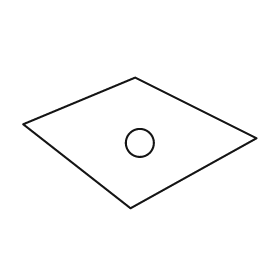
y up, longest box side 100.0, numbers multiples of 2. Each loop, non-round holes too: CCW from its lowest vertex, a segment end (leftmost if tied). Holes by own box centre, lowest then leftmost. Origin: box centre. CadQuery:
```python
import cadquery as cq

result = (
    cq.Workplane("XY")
    .moveTo(-4.0, -28.0)
    .lineTo(50.0, 2.0)
    .lineTo(-2.0, 28.0)
    .lineTo(-50.0, 8.0)
    .close()
    .moveTo(0.0, 0.0)
    .circle(6.0)
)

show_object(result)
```